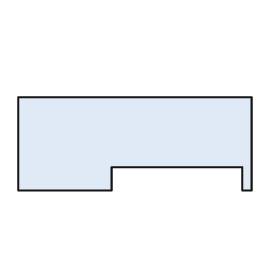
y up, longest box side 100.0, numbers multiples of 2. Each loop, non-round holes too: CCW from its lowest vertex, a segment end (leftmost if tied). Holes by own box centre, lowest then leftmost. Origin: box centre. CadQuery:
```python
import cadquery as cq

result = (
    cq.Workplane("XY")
    .moveTo(-50.0, -20.0)
    .lineTo(-10.0, -20.0)
    .lineTo(-10.0, -10.0)
    .lineTo(46.0, -10.0)
    .lineTo(46.0, -20.0)
    .lineTo(50.0, -20.0)
    .lineTo(50.0, 20.0)
    .lineTo(-50.0, 20.0)
    .close()
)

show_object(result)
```